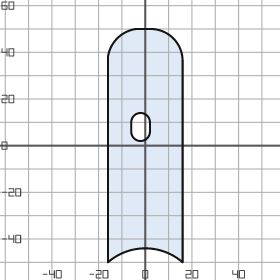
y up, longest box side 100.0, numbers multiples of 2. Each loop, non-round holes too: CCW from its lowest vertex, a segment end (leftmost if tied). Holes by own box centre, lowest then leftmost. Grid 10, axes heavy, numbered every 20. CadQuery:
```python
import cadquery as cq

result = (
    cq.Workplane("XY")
    .moveTo(-16.0, -50.0)
    .threePointArc((0.0, -44.0), (16.0, -50.0))
    .lineTo(16.0, 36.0)
    .threePointArc((12.0, 46.0), (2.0, 50.0))
    .lineTo(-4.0, 50.0)
    .threePointArc((-12.0, 46.0), (-16.0, 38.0))
    .close()
    .moveTo(-6.0, 6.0)
    .threePointArc((-2.0, 2.0), (2.0, 6.0))
    .lineTo(2.0, 10.0)
    .threePointArc((-2.0, 14.0), (-6.0, 10.0))
    .close()
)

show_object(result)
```